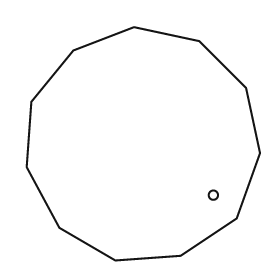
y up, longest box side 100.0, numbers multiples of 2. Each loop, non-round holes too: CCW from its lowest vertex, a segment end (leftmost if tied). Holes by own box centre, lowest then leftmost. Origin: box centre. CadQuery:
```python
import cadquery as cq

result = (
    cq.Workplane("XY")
    .moveTo(-12.0, -50.0)
    .lineTo(16.0, -48.0)
    .lineTo(40.0, -32.0)
    .lineTo(50.0, -4.0)
    .lineTo(44.0, 24.0)
    .lineTo(24.0, 44.0)
    .lineTo(-4.0, 50.0)
    .lineTo(-30.0, 40.0)
    .lineTo(-48.0, 18.0)
    .lineTo(-50.0, -10.0)
    .lineTo(-36.0, -36.0)
    .close()
    .moveTo(30.0, -22.0)
    .circle(2.0)
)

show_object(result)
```